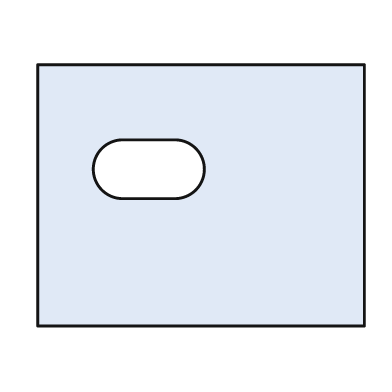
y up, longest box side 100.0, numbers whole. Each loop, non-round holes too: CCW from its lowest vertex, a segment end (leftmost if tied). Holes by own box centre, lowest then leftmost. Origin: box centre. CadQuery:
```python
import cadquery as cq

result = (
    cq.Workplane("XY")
    .moveTo(-50.0, -40.0)
    .lineTo(50.0, -40.0)
    .lineTo(50.0, 40.0)
    .lineTo(-50.0, 40.0)
    .close()
    .moveTo(-24.0, -1.0)
    .lineTo(-8.0, -1.0)
    .threePointArc((1.0, 8.0), (-8.0, 17.0))
    .lineTo(-24.0, 17.0)
    .threePointArc((-33.0, 8.0), (-24.0, -1.0))
    .close()
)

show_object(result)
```